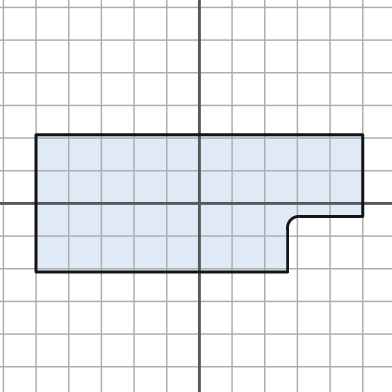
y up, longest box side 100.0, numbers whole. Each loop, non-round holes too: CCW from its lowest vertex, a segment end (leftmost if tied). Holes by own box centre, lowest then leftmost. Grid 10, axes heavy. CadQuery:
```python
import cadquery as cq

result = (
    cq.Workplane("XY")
    .moveTo(-50.0, -21.0)
    .lineTo(27.0, -21.0)
    .lineTo(27.0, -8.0)
    .threePointArc((28.0, -5.0), (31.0, -4.0))
    .lineTo(50.0, -4.0)
    .lineTo(50.0, 21.0)
    .lineTo(-50.0, 21.0)
    .close()
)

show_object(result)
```